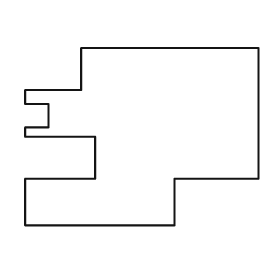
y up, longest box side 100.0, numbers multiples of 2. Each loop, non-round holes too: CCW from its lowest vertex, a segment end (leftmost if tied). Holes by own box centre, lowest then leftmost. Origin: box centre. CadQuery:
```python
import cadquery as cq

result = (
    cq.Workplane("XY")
    .moveTo(-50.0, -38.0)
    .lineTo(14.0, -38.0)
    .lineTo(14.0, -18.0)
    .lineTo(50.0, -18.0)
    .lineTo(50.0, 38.0)
    .lineTo(-26.0, 38.0)
    .lineTo(-26.0, 20.0)
    .lineTo(-50.0, 20.0)
    .lineTo(-50.0, 14.0)
    .lineTo(-40.0, 14.0)
    .lineTo(-40.0, 4.0)
    .lineTo(-50.0, 4.0)
    .lineTo(-50.0, 0.0)
    .lineTo(-20.0, 0.0)
    .lineTo(-20.0, -18.0)
    .lineTo(-50.0, -18.0)
    .close()
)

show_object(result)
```